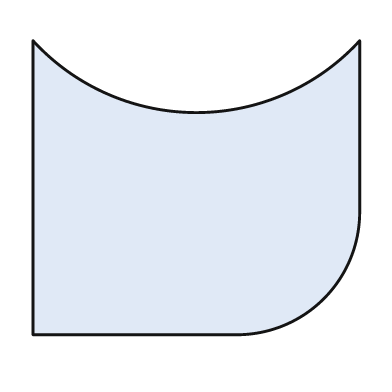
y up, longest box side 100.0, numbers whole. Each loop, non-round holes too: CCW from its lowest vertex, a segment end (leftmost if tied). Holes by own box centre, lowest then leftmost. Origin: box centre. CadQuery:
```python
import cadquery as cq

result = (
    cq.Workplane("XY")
    .moveTo(-50.0, -45.0)
    .lineTo(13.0, -45.0)
    .threePointArc((39.0, -34.0), (50.0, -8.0))
    .lineTo(50.0, 45.0)
    .threePointArc((0.0, 23.0), (-50.0, 45.0))
    .close()
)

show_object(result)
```